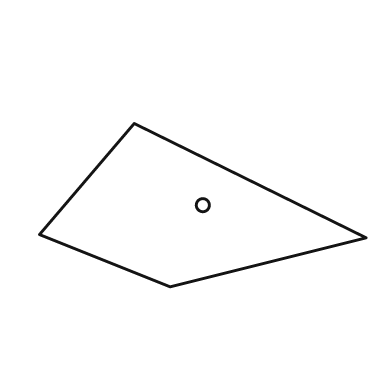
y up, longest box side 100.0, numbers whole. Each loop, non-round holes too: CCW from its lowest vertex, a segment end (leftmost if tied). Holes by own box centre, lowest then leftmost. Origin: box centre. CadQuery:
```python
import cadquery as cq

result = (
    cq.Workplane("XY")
    .moveTo(-10.0, -25.0)
    .lineTo(50.0, -10.0)
    .lineTo(-21.0, 25.0)
    .lineTo(-50.0, -9.0)
    .close()
    .moveTo(0.0, 0.0)
    .circle(2.0)
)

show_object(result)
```